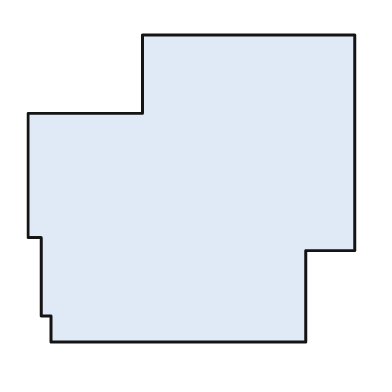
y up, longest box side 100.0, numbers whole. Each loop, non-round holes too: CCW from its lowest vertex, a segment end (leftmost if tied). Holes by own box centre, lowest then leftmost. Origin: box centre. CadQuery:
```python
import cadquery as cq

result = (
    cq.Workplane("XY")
    .moveTo(-43.0, -47.0)
    .lineTo(35.0, -47.0)
    .lineTo(35.0, -19.0)
    .lineTo(50.0, -19.0)
    .lineTo(50.0, 47.0)
    .lineTo(-15.0, 47.0)
    .lineTo(-15.0, 23.0)
    .lineTo(-50.0, 23.0)
    .lineTo(-50.0, -15.0)
    .lineTo(-46.0, -15.0)
    .lineTo(-46.0, -39.0)
    .lineTo(-43.0, -39.0)
    .close()
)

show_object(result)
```